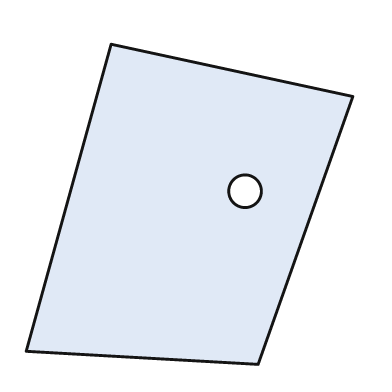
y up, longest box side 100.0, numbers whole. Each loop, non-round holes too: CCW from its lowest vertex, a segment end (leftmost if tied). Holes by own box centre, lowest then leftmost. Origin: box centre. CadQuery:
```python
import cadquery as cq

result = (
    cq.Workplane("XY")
    .moveTo(21.0, -49.0)
    .lineTo(50.0, 33.0)
    .lineTo(-24.0, 49.0)
    .lineTo(-50.0, -45.0)
    .close()
    .moveTo(17.0, 4.0)
    .circle(5.0)
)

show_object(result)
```